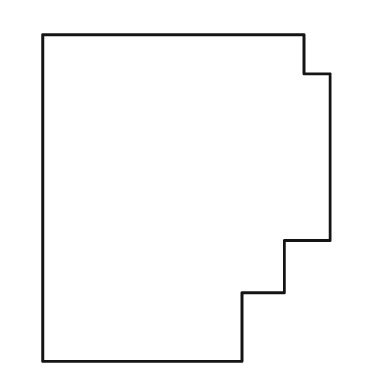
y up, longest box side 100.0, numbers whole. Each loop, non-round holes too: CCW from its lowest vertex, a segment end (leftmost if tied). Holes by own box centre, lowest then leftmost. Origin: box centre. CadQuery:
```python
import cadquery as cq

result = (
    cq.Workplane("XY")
    .moveTo(-44.0, -50.0)
    .lineTo(17.0, -50.0)
    .lineTo(17.0, -29.0)
    .lineTo(30.0, -29.0)
    .lineTo(30.0, -13.0)
    .lineTo(44.0, -13.0)
    .lineTo(44.0, 38.0)
    .lineTo(36.0, 38.0)
    .lineTo(36.0, 50.0)
    .lineTo(-44.0, 50.0)
    .close()
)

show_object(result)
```